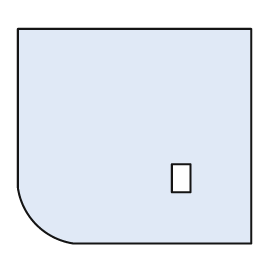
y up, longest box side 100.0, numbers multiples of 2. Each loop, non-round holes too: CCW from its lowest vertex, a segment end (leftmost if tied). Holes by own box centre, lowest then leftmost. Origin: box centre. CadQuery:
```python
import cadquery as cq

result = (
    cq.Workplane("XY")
    .moveTo(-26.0, -46.0)
    .lineTo(50.0, -46.0)
    .lineTo(50.0, 46.0)
    .lineTo(-50.0, 46.0)
    .lineTo(-50.0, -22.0)
    .threePointArc((-42.0, -38.0), (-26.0, -46.0))
    .close()
    .moveTo(16.0, -24.0)
    .lineTo(24.0, -24.0)
    .lineTo(24.0, -12.0)
    .lineTo(16.0, -12.0)
    .close()
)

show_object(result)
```